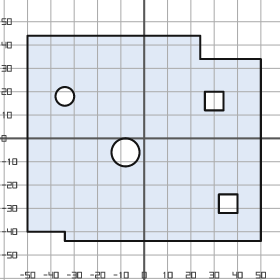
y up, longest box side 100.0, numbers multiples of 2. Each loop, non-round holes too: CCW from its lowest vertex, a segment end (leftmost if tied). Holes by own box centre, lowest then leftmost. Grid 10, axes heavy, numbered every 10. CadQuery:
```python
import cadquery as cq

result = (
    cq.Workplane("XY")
    .moveTo(-34.0, -44.0)
    .lineTo(50.0, -44.0)
    .lineTo(50.0, 34.0)
    .lineTo(24.0, 34.0)
    .lineTo(24.0, 44.0)
    .lineTo(-50.0, 44.0)
    .lineTo(-50.0, -40.0)
    .lineTo(-34.0, -40.0)
    .close()
    .moveTo(32.0, -32.0)
    .lineTo(40.0, -32.0)
    .lineTo(40.0, -24.0)
    .lineTo(32.0, -24.0)
    .close()
    .moveTo(-8.0, -6.0)
    .circle(6.0)
    .moveTo(26.0, 12.0)
    .lineTo(34.0, 12.0)
    .lineTo(34.0, 20.0)
    .lineTo(26.0, 20.0)
    .close()
    .moveTo(-34.0, 18.0)
    .circle(4.0)
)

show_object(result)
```